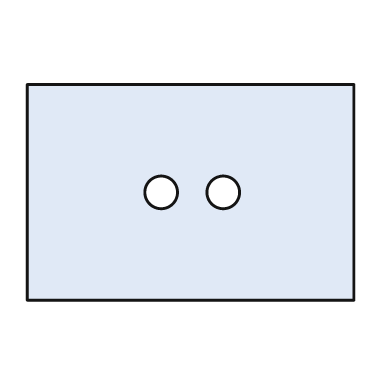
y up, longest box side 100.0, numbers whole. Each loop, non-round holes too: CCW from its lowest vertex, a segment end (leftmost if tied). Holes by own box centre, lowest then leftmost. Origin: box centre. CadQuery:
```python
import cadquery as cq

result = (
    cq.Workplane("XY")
    .moveTo(-50.0, -33.0)
    .lineTo(50.0, -33.0)
    .lineTo(50.0, 33.0)
    .lineTo(-50.0, 33.0)
    .close()
    .moveTo(-9.0, 0.0)
    .circle(5.0)
    .moveTo(10.0, 0.0)
    .circle(5.0)
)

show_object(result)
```